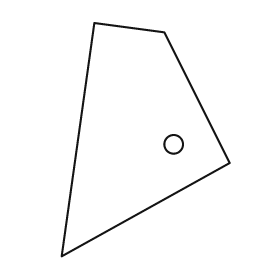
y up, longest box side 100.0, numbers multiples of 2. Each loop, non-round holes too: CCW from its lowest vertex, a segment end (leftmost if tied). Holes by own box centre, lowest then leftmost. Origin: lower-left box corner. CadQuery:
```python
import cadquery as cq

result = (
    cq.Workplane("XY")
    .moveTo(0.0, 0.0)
    .lineTo(72.0, 40.0)
    .lineTo(44.0, 96.0)
    .lineTo(14.0, 100.0)
    .close()
    .moveTo(48.0, 48.0)
    .circle(4.0)
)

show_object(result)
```